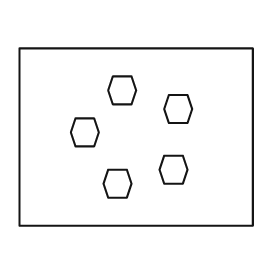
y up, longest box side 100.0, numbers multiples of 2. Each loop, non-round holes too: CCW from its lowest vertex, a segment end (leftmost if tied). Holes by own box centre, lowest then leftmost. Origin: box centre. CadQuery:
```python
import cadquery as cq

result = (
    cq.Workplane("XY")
    .moveTo(-50.0, -38.0)
    .lineTo(50.0, -38.0)
    .lineTo(50.0, 38.0)
    .lineTo(-50.0, 38.0)
    .close()
    .moveTo(-12.0, -26.0)
    .lineTo(-4.0, -26.0)
    .lineTo(-2.0, -20.0)
    .lineTo(-4.0, -14.0)
    .lineTo(-12.0, -14.0)
    .lineTo(-14.0, -20.0)
    .close()
    .moveTo(12.0, -20.0)
    .lineTo(20.0, -20.0)
    .lineTo(22.0, -14.0)
    .lineTo(20.0, -8.0)
    .lineTo(12.0, -8.0)
    .lineTo(10.0, -14.0)
    .close()
    .moveTo(-26.0, -4.0)
    .lineTo(-18.0, -4.0)
    .lineTo(-16.0, 2.0)
    .lineTo(-18.0, 8.0)
    .lineTo(-26.0, 8.0)
    .lineTo(-28.0, 2.0)
    .close()
    .moveTo(14.0, 6.0)
    .lineTo(22.0, 6.0)
    .lineTo(24.0, 12.0)
    .lineTo(22.0, 18.0)
    .lineTo(14.0, 18.0)
    .lineTo(12.0, 12.0)
    .close()
    .moveTo(-10.0, 14.0)
    .lineTo(-2.0, 14.0)
    .lineTo(0.0, 20.0)
    .lineTo(-2.0, 26.0)
    .lineTo(-10.0, 26.0)
    .lineTo(-12.0, 20.0)
    .close()
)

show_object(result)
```